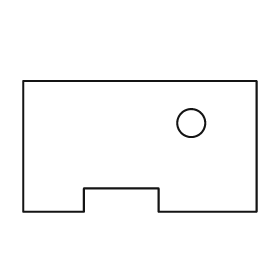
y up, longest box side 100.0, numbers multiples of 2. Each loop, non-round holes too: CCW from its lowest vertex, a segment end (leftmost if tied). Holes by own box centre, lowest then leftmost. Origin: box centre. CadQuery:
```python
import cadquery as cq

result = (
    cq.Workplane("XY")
    .moveTo(-50.0, -28.0)
    .lineTo(-24.0, -28.0)
    .lineTo(-24.0, -18.0)
    .lineTo(8.0, -18.0)
    .lineTo(8.0, -28.0)
    .lineTo(50.0, -28.0)
    .lineTo(50.0, 28.0)
    .lineTo(-50.0, 28.0)
    .close()
    .moveTo(22.0, 10.0)
    .circle(6.0)
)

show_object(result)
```